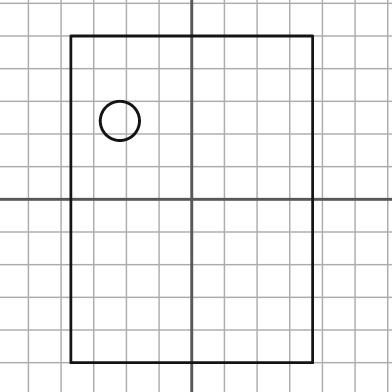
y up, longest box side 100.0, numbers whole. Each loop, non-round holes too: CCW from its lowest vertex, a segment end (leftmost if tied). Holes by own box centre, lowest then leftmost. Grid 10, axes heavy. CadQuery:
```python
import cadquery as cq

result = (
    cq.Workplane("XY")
    .moveTo(-37.0, -50.0)
    .lineTo(37.0, -50.0)
    .lineTo(37.0, 50.0)
    .lineTo(-37.0, 50.0)
    .close()
    .moveTo(-22.0, 24.0)
    .circle(6.0)
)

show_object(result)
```